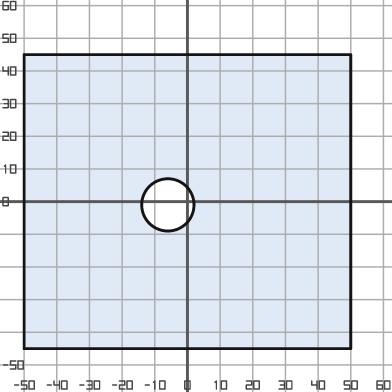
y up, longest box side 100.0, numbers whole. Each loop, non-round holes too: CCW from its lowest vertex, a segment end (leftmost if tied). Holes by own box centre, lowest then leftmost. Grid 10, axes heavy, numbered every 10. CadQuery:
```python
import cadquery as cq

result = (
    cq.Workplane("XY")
    .moveTo(-50.0, -45.0)
    .lineTo(50.0, -45.0)
    .lineTo(50.0, 45.0)
    .lineTo(-50.0, 45.0)
    .close()
    .moveTo(-6.0, -1.0)
    .circle(8.0)
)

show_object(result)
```